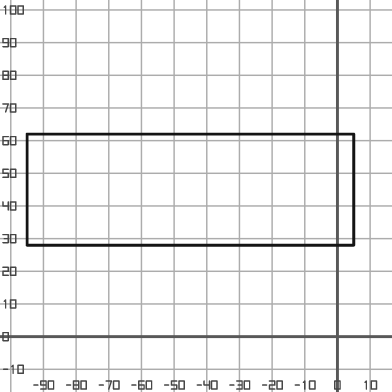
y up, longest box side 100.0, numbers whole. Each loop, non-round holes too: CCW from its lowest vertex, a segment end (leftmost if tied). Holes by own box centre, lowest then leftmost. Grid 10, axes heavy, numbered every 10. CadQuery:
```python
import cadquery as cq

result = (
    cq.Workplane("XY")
    .moveTo(-95.0, 28.0)
    .lineTo(5.0, 28.0)
    .lineTo(5.0, 62.0)
    .lineTo(-95.0, 62.0)
    .close()
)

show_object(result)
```